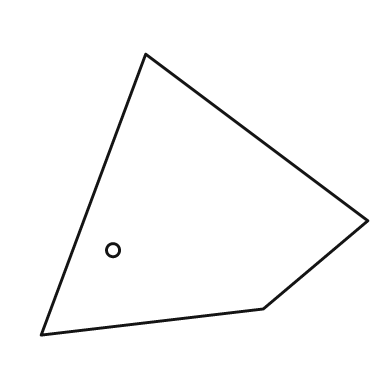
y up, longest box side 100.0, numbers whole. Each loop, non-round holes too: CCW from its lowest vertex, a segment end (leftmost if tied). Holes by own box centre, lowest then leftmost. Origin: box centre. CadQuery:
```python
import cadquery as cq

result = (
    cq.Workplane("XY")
    .moveTo(-50.0, -43.0)
    .lineTo(18.0, -35.0)
    .lineTo(50.0, -8.0)
    .lineTo(-18.0, 43.0)
    .close()
    .moveTo(-28.0, -17.0)
    .circle(2.0)
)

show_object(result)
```